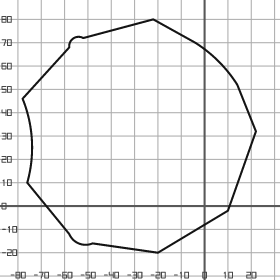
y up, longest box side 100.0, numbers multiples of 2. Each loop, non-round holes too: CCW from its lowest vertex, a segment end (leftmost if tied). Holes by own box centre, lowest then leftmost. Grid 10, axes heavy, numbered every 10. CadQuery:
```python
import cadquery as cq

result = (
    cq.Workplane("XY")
    .moveTo(-20.0, -20.0)
    .lineTo(10.0, -2.0)
    .lineTo(22.0, 32.0)
    .lineTo(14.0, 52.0)
    .threePointArc((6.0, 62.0), (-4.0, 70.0))
    .lineTo(-22.0, 80.0)
    .lineTo(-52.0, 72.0)
    .threePointArc((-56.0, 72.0), (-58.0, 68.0))
    .lineTo(-78.0, 46.0)
    .threePointArc((-74.0, 28.0), (-76.0, 10.0))
    .lineTo(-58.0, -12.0)
    .threePointArc((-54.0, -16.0), (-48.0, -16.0))
    .close()
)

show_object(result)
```